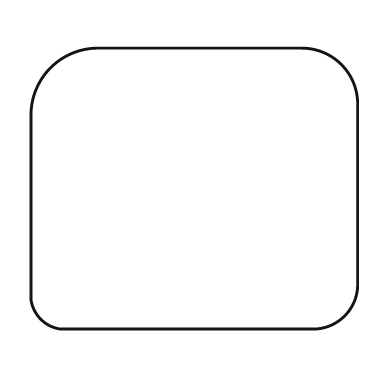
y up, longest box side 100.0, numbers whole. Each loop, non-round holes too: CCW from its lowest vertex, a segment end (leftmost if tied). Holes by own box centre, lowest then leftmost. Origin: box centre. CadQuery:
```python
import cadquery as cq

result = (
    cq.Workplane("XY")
    .moveTo(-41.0, -43.0)
    .lineTo(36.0, -43.0)
    .threePointArc((46.0, -39.0), (50.0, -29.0))
    .lineTo(50.0, 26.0)
    .threePointArc((45.0, 38.0), (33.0, 43.0))
    .lineTo(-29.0, 43.0)
    .threePointArc((-44.0, 37.0), (-50.0, 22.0))
    .lineTo(-50.0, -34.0)
    .threePointArc((-47.0, -40.0), (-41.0, -43.0))
    .close()
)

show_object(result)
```